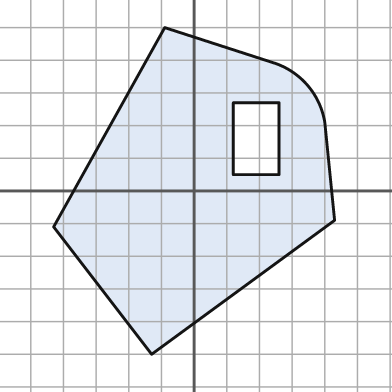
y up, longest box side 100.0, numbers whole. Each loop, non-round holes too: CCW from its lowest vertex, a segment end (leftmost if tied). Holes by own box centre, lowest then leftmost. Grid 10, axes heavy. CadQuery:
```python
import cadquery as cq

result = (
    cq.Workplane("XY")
    .moveTo(-13.0, -50.0)
    .lineTo(43.0, -9.0)
    .lineTo(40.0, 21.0)
    .threePointArc((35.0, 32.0), (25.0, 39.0))
    .lineTo(-9.0, 50.0)
    .lineTo(-43.0, -11.0)
    .close()
    .moveTo(12.0, 5.0)
    .lineTo(26.0, 5.0)
    .lineTo(26.0, 27.0)
    .lineTo(12.0, 27.0)
    .close()
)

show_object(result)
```